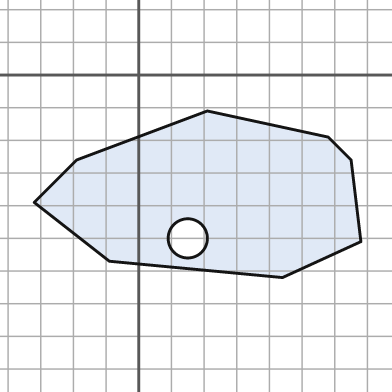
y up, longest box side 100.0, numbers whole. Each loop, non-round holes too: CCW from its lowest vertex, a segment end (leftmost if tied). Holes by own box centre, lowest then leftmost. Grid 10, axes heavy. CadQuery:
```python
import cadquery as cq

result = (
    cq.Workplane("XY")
    .moveTo(44.0, -62.0)
    .lineTo(68.0, -51.0)
    .lineTo(65.0, -26.0)
    .lineTo(58.0, -19.0)
    .lineTo(21.0, -11.0)
    .lineTo(-19.0, -26.0)
    .lineTo(-32.0, -39.0)
    .lineTo(-9.0, -57.0)
    .close()
    .moveTo(15.0, -50.0)
    .circle(6.0)
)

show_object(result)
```